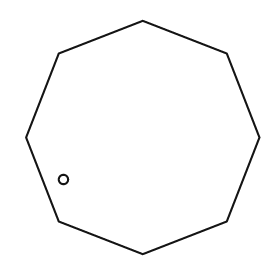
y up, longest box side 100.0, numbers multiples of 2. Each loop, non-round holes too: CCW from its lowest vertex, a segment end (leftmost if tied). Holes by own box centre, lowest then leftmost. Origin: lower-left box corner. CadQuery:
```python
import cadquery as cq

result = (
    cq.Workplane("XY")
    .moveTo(50.0, 0.0)
    .lineTo(86.0, 14.0)
    .lineTo(100.0, 50.0)
    .lineTo(86.0, 86.0)
    .lineTo(50.0, 100.0)
    .lineTo(14.0, 86.0)
    .lineTo(0.0, 50.0)
    .lineTo(14.0, 14.0)
    .close()
    .moveTo(16.0, 32.0)
    .circle(2.0)
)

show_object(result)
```